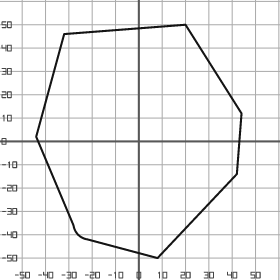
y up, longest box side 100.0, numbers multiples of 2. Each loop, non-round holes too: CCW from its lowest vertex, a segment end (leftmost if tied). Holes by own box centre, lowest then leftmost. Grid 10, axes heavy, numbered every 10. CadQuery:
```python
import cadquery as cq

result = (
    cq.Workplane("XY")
    .moveTo(8.0, -50.0)
    .lineTo(42.0, -14.0)
    .lineTo(44.0, 12.0)
    .lineTo(20.0, 50.0)
    .lineTo(-32.0, 46.0)
    .lineTo(-44.0, 2.0)
    .lineTo(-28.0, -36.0)
    .threePointArc((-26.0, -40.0), (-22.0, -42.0))
    .close()
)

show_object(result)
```